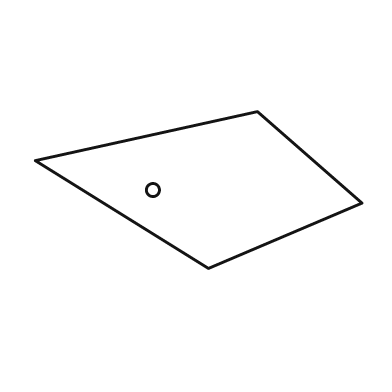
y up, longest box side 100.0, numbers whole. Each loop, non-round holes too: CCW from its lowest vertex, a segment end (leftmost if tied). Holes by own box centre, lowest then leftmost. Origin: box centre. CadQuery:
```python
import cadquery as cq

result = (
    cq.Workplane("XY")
    .moveTo(3.0, -24.0)
    .lineTo(50.0, -4.0)
    .lineTo(18.0, 24.0)
    .lineTo(-50.0, 9.0)
    .close()
    .moveTo(-14.0, 0.0)
    .circle(2.0)
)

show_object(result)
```